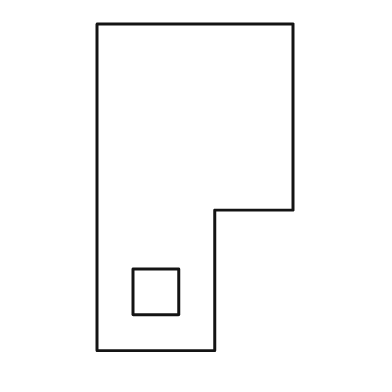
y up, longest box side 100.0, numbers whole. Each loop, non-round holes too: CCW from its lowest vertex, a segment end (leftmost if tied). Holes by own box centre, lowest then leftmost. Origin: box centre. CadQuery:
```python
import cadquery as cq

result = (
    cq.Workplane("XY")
    .moveTo(-30.0, -50.0)
    .lineTo(6.0, -50.0)
    .lineTo(6.0, -7.0)
    .lineTo(30.0, -7.0)
    .lineTo(30.0, 50.0)
    .lineTo(-30.0, 50.0)
    .close()
    .moveTo(-19.0, -39.0)
    .lineTo(-5.0, -39.0)
    .lineTo(-5.0, -25.0)
    .lineTo(-19.0, -25.0)
    .close()
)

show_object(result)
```